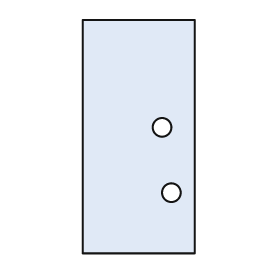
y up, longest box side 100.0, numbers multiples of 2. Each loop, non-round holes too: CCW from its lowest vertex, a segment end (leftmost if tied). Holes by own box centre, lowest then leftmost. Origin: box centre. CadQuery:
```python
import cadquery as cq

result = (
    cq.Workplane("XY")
    .moveTo(-24.0, -50.0)
    .lineTo(24.0, -50.0)
    .lineTo(24.0, 50.0)
    .lineTo(-24.0, 50.0)
    .close()
    .moveTo(14.0, -24.0)
    .circle(4.0)
    .moveTo(10.0, 4.0)
    .circle(4.0)
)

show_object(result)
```